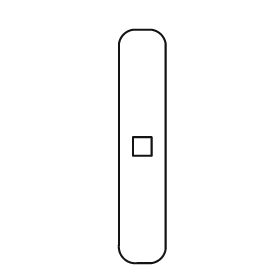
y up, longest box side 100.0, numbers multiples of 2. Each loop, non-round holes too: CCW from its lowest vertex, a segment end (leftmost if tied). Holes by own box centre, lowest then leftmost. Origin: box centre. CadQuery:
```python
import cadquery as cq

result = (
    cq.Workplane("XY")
    .moveTo(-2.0, -50.0)
    .lineTo(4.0, -50.0)
    .threePointArc((8.0, -48.0), (10.0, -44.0))
    .lineTo(10.0, 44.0)
    .threePointArc((8.0, 48.0), (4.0, 50.0))
    .lineTo(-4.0, 50.0)
    .threePointArc((-8.0, 48.0), (-10.0, 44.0))
    .lineTo(-10.0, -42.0)
    .threePointArc((-8.0, -48.0), (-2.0, -50.0))
    .close()
    .moveTo(-4.0, -4.0)
    .lineTo(4.0, -4.0)
    .lineTo(4.0, 4.0)
    .lineTo(-4.0, 4.0)
    .close()
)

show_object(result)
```